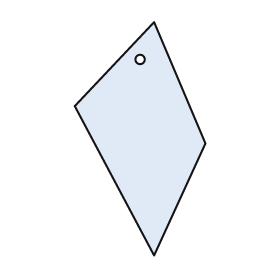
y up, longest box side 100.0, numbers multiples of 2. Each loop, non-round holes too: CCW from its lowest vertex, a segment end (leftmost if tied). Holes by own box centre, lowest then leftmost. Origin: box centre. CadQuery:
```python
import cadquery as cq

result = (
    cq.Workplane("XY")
    .moveTo(6.0, -50.0)
    .lineTo(28.0, -2.0)
    .lineTo(6.0, 50.0)
    .lineTo(-28.0, 14.0)
    .close()
    .moveTo(0.0, 34.0)
    .circle(2.0)
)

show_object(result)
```